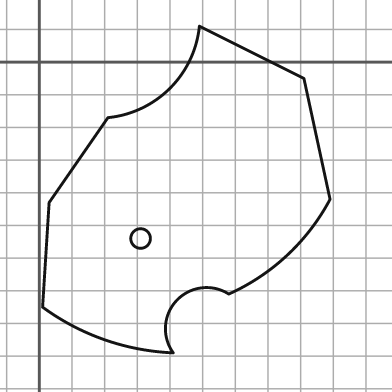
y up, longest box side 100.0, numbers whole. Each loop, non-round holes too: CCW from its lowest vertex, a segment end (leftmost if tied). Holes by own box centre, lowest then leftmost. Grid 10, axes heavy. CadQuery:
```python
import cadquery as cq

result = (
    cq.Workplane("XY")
    .moveTo(41.0, -89.0)
    .threePointArc((42.0, -73.0), (58.0, -71.0))
    .threePointArc((76.0, -59.0), (89.0, -42.0))
    .lineTo(81.0, -5.0)
    .lineTo(49.0, 11.0)
    .threePointArc((40.0, -8.0), (21.0, -17.0))
    .lineTo(3.0, -43.0)
    .lineTo(1.0, -75.0)
    .threePointArc((20.0, -85.0), (41.0, -89.0))
    .close()
    .moveTo(31.0, -54.0)
    .circle(3.0)
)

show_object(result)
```